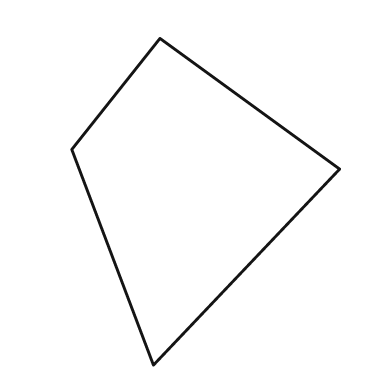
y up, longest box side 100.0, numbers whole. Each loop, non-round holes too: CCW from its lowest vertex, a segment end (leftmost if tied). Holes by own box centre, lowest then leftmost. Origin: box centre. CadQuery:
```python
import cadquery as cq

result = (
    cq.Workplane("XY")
    .moveTo(-16.0, -50.0)
    .lineTo(41.0, 10.0)
    .lineTo(-14.0, 50.0)
    .lineTo(-41.0, 16.0)
    .close()
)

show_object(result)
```